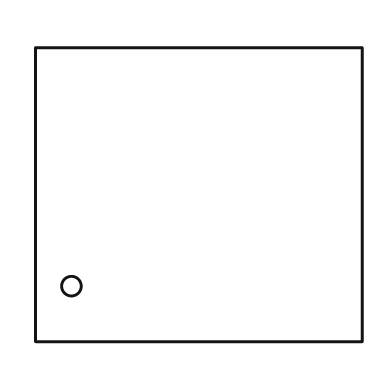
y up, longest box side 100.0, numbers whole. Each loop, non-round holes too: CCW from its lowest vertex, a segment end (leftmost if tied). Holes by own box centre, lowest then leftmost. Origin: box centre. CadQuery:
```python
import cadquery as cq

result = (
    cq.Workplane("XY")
    .moveTo(-50.0, -45.0)
    .lineTo(50.0, -45.0)
    .lineTo(50.0, 45.0)
    .lineTo(-50.0, 45.0)
    .close()
    .moveTo(-39.0, -28.0)
    .circle(3.0)
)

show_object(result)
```